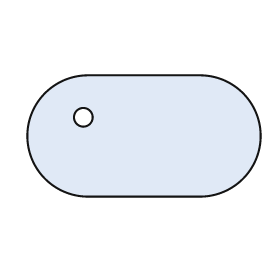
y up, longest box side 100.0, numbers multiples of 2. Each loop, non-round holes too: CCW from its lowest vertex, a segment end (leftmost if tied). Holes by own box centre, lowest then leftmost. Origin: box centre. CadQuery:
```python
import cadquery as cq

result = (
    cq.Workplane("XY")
    .moveTo(-24.0, -26.0)
    .lineTo(24.0, -26.0)
    .threePointArc((50.0, 0.0), (24.0, 26.0))
    .lineTo(-24.0, 26.0)
    .threePointArc((-50.0, 0.0), (-24.0, -26.0))
    .close()
    .moveTo(-26.0, 8.0)
    .circle(4.0)
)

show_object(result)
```